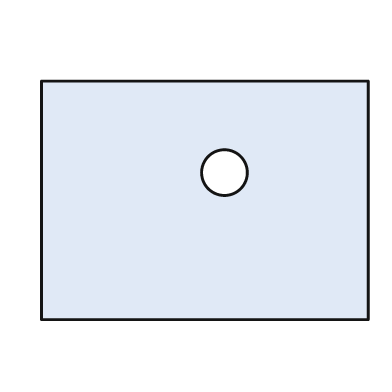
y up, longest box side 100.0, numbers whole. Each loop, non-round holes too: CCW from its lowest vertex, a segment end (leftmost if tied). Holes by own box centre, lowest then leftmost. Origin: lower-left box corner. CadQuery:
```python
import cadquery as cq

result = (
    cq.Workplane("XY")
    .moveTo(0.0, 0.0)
    .lineTo(100.0, 0.0)
    .lineTo(100.0, 73.0)
    .lineTo(0.0, 73.0)
    .close()
    .moveTo(56.0, 45.0)
    .circle(7.0)
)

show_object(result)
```